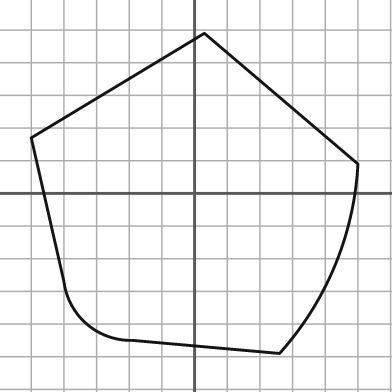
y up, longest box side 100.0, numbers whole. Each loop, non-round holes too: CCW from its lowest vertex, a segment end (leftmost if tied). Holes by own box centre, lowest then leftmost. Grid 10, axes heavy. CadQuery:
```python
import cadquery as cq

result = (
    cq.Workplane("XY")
    .moveTo(26.0, -49.0)
    .threePointArc((43.0, -22.0), (50.0, 9.0))
    .lineTo(3.0, 49.0)
    .lineTo(-50.0, 17.0)
    .lineTo(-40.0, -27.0)
    .threePointArc((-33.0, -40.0), (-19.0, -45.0))
    .close()
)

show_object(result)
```